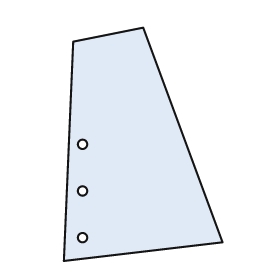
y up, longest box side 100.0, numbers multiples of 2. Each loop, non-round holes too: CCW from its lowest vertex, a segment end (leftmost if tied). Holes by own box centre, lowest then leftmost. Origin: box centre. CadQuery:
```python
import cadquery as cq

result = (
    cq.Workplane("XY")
    .moveTo(-34.0, -50.0)
    .lineTo(34.0, -42.0)
    .lineTo(0.0, 50.0)
    .lineTo(-30.0, 44.0)
    .close()
    .moveTo(-26.0, -40.0)
    .circle(2.0)
    .moveTo(-26.0, -20.0)
    .circle(2.0)
    .moveTo(-26.0, 0.0)
    .circle(2.0)
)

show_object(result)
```